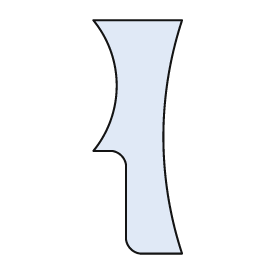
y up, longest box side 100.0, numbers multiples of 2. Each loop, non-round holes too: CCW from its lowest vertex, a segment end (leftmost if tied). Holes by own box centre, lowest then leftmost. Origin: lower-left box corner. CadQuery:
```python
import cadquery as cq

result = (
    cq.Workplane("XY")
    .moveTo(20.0, 0.0)
    .lineTo(38.0, 0.0)
    .threePointArc((30.0, 50.0), (38.0, 100.0))
    .lineTo(0.0, 100.0)
    .threePointArc((10.0, 72.0), (0.0, 44.0))
    .lineTo(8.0, 44.0)
    .threePointArc((12.0, 42.0), (14.0, 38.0))
    .lineTo(14.0, 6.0)
    .threePointArc((16.0, 2.0), (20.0, 0.0))
    .close()
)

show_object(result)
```